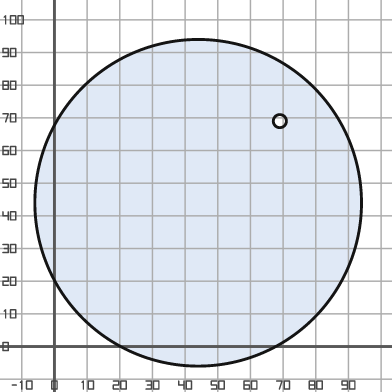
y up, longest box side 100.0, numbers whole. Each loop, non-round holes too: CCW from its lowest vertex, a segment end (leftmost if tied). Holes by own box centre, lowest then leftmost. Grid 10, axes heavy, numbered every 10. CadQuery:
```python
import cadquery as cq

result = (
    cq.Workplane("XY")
    .moveTo(44.0, 44.0)
    .circle(50.0)
    .moveTo(69.0, 69.0)
    .circle(2.0)
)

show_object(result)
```